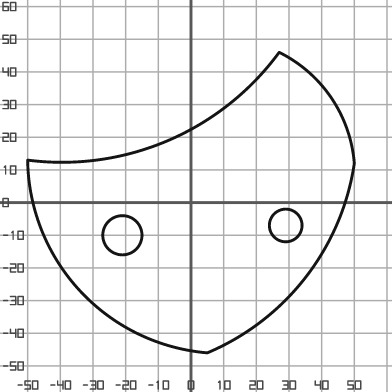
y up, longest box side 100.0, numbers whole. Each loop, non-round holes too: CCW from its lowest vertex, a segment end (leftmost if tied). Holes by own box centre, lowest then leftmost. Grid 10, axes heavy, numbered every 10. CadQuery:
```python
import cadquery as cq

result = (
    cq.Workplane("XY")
    .moveTo(5.0, -46.0)
    .threePointArc((35.0, -23.0), (50.0, 12.0))
    .threePointArc((43.0, 32.0), (27.0, 46.0))
    .threePointArc((-7.0, 19.0), (-50.0, 13.0))
    .threePointArc((-34.0, -27.0), (5.0, -46.0))
    .close()
    .moveTo(-21.0, -10.0)
    .circle(6.0)
    .moveTo(29.0, -7.0)
    .circle(5.0)
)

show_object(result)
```